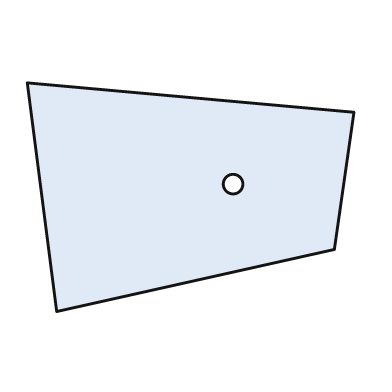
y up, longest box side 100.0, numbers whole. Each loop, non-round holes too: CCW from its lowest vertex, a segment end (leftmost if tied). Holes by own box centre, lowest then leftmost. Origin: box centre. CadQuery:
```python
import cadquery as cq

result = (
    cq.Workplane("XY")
    .moveTo(-41.0, -35.0)
    .lineTo(44.0, -16.0)
    .lineTo(50.0, 26.0)
    .lineTo(-50.0, 35.0)
    .close()
    .moveTo(13.0, 4.0)
    .circle(3.0)
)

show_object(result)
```